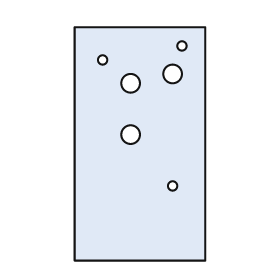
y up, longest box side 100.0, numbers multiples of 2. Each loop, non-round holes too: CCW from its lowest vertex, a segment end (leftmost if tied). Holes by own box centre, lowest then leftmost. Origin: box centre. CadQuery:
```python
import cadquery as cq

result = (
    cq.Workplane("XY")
    .moveTo(-28.0, -50.0)
    .lineTo(28.0, -50.0)
    .lineTo(28.0, 50.0)
    .lineTo(-28.0, 50.0)
    .close()
    .moveTo(14.0, -18.0)
    .circle(2.0)
    .moveTo(-4.0, 4.0)
    .circle(4.0)
    .moveTo(-4.0, 26.0)
    .circle(4.0)
    .moveTo(14.0, 30.0)
    .circle(4.0)
    .moveTo(-16.0, 36.0)
    .circle(2.0)
    .moveTo(18.0, 42.0)
    .circle(2.0)
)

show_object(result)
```